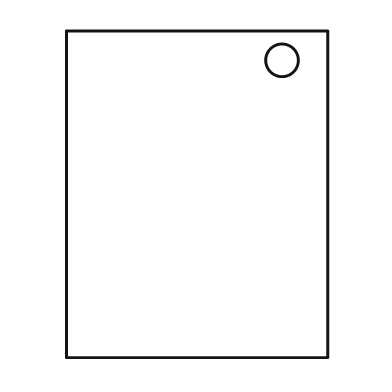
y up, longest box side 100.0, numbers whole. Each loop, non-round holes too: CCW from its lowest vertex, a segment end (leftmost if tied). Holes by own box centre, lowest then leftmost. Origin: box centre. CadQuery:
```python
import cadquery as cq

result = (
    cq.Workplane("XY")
    .moveTo(-40.0, -50.0)
    .lineTo(40.0, -50.0)
    .lineTo(40.0, 50.0)
    .lineTo(-40.0, 50.0)
    .close()
    .moveTo(26.0, 41.0)
    .circle(5.0)
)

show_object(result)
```